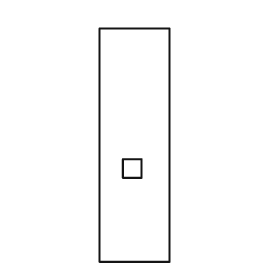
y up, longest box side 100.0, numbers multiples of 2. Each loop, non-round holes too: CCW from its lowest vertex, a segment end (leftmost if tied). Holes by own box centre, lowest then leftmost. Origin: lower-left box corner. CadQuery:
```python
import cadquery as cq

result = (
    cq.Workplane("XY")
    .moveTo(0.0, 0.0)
    .lineTo(30.0, 0.0)
    .lineTo(30.0, 100.0)
    .lineTo(0.0, 100.0)
    .close()
    .moveTo(10.0, 36.0)
    .lineTo(18.0, 36.0)
    .lineTo(18.0, 44.0)
    .lineTo(10.0, 44.0)
    .close()
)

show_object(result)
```